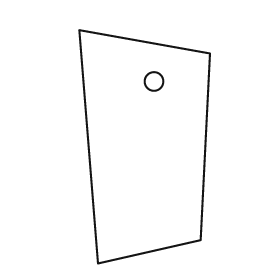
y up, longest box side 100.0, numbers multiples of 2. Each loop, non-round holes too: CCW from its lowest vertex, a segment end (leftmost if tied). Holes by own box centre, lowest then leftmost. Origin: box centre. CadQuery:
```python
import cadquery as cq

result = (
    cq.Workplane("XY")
    .moveTo(-20.0, -50.0)
    .lineTo(24.0, -40.0)
    .lineTo(28.0, 40.0)
    .lineTo(-28.0, 50.0)
    .close()
    .moveTo(4.0, 28.0)
    .circle(4.0)
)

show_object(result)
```